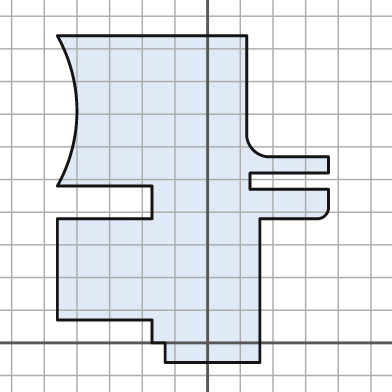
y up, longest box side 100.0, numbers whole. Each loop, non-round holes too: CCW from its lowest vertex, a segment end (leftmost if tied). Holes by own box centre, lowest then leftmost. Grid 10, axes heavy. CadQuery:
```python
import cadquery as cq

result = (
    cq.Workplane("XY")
    .moveTo(-13.0, -6.0)
    .lineTo(16.0, -6.0)
    .lineTo(16.0, 38.0)
    .lineTo(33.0, 38.0)
    .threePointArc((36.0, 39.0), (37.0, 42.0))
    .lineTo(37.0, 47.0)
    .lineTo(13.0, 47.0)
    .lineTo(13.0, 52.0)
    .lineTo(37.0, 52.0)
    .lineTo(37.0, 57.0)
    .lineTo(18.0, 57.0)
    .threePointArc((14.0, 59.0), (12.0, 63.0))
    .lineTo(12.0, 94.0)
    .lineTo(-46.0, 94.0)
    .threePointArc((-40.0, 71.0), (-46.0, 48.0))
    .lineTo(-17.0, 48.0)
    .lineTo(-17.0, 38.0)
    .lineTo(-46.0, 38.0)
    .lineTo(-46.0, 7.0)
    .lineTo(-17.0, 7.0)
    .lineTo(-17.0, 0.0)
    .lineTo(-13.0, 0.0)
    .close()
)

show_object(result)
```